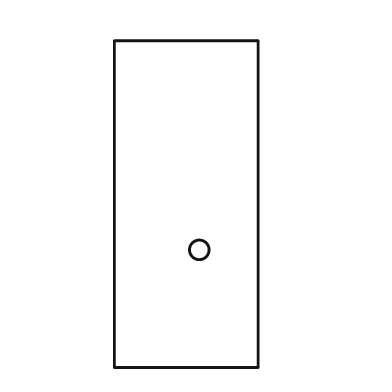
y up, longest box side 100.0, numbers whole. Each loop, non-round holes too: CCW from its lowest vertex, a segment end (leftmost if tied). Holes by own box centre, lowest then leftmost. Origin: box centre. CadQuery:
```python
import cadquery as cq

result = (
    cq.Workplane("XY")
    .moveTo(-22.0, -50.0)
    .lineTo(22.0, -50.0)
    .lineTo(22.0, 50.0)
    .lineTo(-22.0, 50.0)
    .close()
    .moveTo(4.0, -14.0)
    .circle(3.0)
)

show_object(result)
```